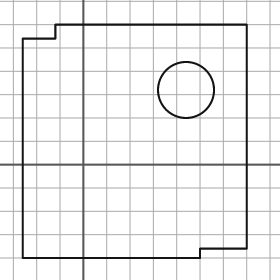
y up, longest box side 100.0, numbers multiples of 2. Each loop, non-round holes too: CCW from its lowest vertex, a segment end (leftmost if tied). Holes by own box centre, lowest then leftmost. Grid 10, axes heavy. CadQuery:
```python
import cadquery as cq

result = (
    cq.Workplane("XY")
    .moveTo(-26.0, -40.0)
    .lineTo(50.0, -40.0)
    .lineTo(50.0, -36.0)
    .lineTo(70.0, -36.0)
    .lineTo(70.0, 60.0)
    .lineTo(-12.0, 60.0)
    .lineTo(-12.0, 54.0)
    .lineTo(-26.0, 54.0)
    .close()
    .moveTo(44.0, 32.0)
    .circle(12.0)
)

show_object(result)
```